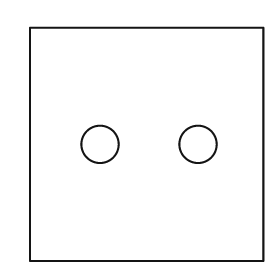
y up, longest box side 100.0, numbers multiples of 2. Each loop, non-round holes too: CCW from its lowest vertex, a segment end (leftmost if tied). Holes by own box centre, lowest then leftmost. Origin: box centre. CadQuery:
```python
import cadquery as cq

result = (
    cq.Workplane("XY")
    .moveTo(-50.0, -50.0)
    .lineTo(50.0, -50.0)
    .lineTo(50.0, 50.0)
    .lineTo(-50.0, 50.0)
    .close()
    .moveTo(-20.0, 0.0)
    .circle(8.0)
    .moveTo(22.0, 0.0)
    .circle(8.0)
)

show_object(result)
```